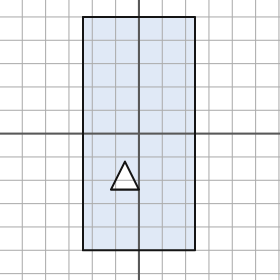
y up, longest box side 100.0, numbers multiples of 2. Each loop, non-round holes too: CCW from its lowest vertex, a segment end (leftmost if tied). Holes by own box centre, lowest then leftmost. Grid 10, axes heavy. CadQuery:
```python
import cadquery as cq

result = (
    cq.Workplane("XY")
    .moveTo(-24.0, -50.0)
    .lineTo(24.0, -50.0)
    .lineTo(24.0, 50.0)
    .lineTo(-24.0, 50.0)
    .close()
    .moveTo(-12.0, -24.0)
    .lineTo(0.0, -24.0)
    .lineTo(-6.0, -12.0)
    .close()
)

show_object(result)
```